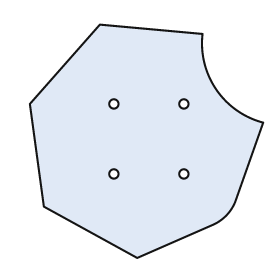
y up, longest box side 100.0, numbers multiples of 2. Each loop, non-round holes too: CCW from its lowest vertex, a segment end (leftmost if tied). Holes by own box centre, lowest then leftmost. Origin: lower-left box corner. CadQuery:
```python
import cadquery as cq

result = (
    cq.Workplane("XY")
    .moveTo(46.0, 0.0)
    .lineTo(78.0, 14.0)
    .threePointArc((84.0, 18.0), (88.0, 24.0))
    .lineTo(100.0, 58.0)
    .threePointArc((80.0, 72.0), (74.0, 96.0))
    .lineTo(30.0, 100.0)
    .lineTo(0.0, 66.0)
    .lineTo(6.0, 22.0)
    .close()
    .moveTo(36.0, 36.0)
    .circle(2.0)
    .moveTo(66.0, 36.0)
    .circle(2.0)
    .moveTo(36.0, 66.0)
    .circle(2.0)
    .moveTo(66.0, 66.0)
    .circle(2.0)
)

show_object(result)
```